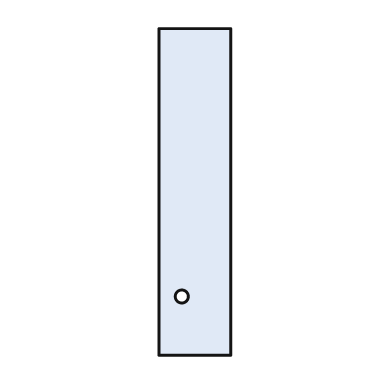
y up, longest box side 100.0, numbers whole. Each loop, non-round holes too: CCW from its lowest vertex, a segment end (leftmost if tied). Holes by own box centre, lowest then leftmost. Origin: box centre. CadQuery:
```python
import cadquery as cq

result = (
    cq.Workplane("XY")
    .moveTo(-11.0, -50.0)
    .lineTo(11.0, -50.0)
    .lineTo(11.0, 50.0)
    .lineTo(-11.0, 50.0)
    .close()
    .moveTo(-4.0, -32.0)
    .circle(2.0)
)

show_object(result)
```